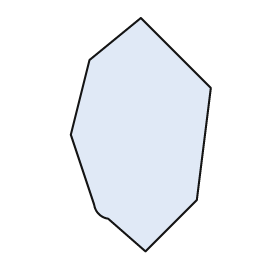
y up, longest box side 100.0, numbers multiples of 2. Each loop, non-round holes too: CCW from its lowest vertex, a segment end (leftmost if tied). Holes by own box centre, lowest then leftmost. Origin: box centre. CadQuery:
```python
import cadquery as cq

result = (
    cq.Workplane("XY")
    .moveTo(2.0, -50.0)
    .lineTo(24.0, -28.0)
    .lineTo(30.0, 20.0)
    .lineTo(0.0, 50.0)
    .lineTo(-22.0, 32.0)
    .lineTo(-30.0, 0.0)
    .lineTo(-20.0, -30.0)
    .threePointArc((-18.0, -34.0), (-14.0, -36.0))
    .close()
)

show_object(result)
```